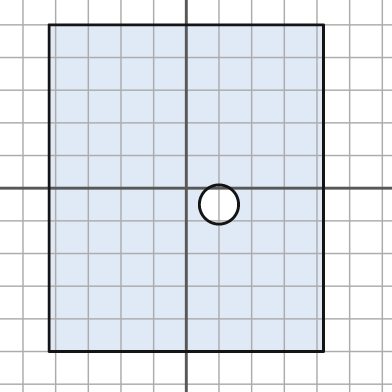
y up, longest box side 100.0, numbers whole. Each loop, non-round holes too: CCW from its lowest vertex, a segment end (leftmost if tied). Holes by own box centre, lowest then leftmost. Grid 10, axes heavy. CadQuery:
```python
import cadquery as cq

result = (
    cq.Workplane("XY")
    .moveTo(-42.0, -50.0)
    .lineTo(42.0, -50.0)
    .lineTo(42.0, 50.0)
    .lineTo(-42.0, 50.0)
    .close()
    .moveTo(10.0, -5.0)
    .circle(6.0)
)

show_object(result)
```